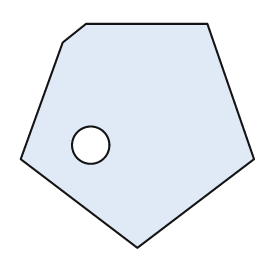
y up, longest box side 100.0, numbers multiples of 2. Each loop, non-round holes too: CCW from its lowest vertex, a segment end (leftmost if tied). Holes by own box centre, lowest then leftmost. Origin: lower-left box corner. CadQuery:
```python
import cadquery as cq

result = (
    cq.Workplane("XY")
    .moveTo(50.0, 0.0)
    .lineTo(100.0, 38.0)
    .lineTo(80.0, 96.0)
    .lineTo(28.0, 96.0)
    .lineTo(18.0, 88.0)
    .lineTo(0.0, 38.0)
    .close()
    .moveTo(30.0, 44.0)
    .circle(8.0)
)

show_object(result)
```